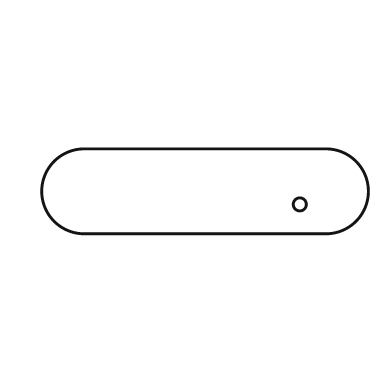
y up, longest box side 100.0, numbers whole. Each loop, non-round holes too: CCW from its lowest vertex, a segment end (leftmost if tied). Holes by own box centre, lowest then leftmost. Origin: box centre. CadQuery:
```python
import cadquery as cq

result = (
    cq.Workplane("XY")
    .moveTo(-37.0, -13.0)
    .lineTo(37.0, -13.0)
    .threePointArc((50.0, 0.0), (37.0, 13.0))
    .lineTo(-37.0, 13.0)
    .threePointArc((-50.0, 0.0), (-37.0, -13.0))
    .close()
    .moveTo(29.0, -4.0)
    .circle(2.0)
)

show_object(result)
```